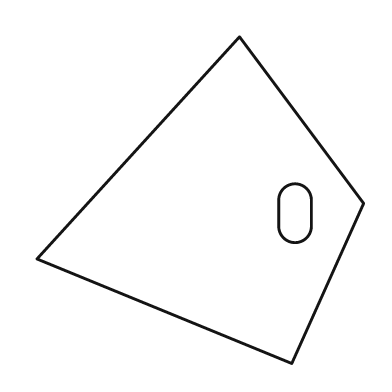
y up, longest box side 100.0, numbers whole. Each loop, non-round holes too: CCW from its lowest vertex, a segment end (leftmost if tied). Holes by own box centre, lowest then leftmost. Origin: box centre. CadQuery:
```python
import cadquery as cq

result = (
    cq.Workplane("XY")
    .moveTo(28.0, -50.0)
    .lineTo(50.0, -1.0)
    .lineTo(12.0, 50.0)
    .lineTo(-50.0, -18.0)
    .close()
    .moveTo(24.0, -8.0)
    .threePointArc((29.0, -13.0), (34.0, -8.0))
    .lineTo(34.0, 0.0)
    .threePointArc((29.0, 5.0), (24.0, 0.0))
    .close()
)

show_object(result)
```